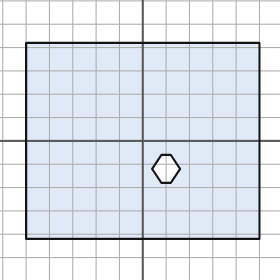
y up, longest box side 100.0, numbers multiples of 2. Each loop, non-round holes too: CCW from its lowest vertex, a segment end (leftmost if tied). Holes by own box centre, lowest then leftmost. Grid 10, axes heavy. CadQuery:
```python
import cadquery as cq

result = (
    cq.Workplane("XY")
    .moveTo(-50.0, -42.0)
    .lineTo(50.0, -42.0)
    .lineTo(50.0, 42.0)
    .lineTo(-50.0, 42.0)
    .close()
    .moveTo(8.0, -18.0)
    .lineTo(12.0, -18.0)
    .lineTo(16.0, -12.0)
    .lineTo(12.0, -6.0)
    .lineTo(8.0, -6.0)
    .lineTo(4.0, -12.0)
    .close()
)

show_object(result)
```